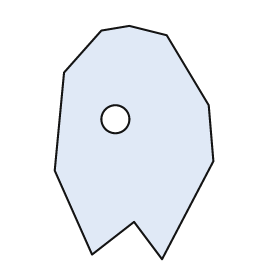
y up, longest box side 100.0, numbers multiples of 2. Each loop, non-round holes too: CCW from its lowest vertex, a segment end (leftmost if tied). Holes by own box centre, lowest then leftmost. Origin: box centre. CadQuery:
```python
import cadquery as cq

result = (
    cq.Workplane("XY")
    .moveTo(12.0, -50.0)
    .lineTo(34.0, -8.0)
    .lineTo(32.0, 16.0)
    .lineTo(14.0, 46.0)
    .lineTo(-2.0, 50.0)
    .lineTo(-14.0, 48.0)
    .lineTo(-30.0, 30.0)
    .lineTo(-34.0, -12.0)
    .lineTo(-18.0, -48.0)
    .lineTo(0.0, -34.0)
    .close()
    .moveTo(-8.0, 10.0)
    .circle(6.0)
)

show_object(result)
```